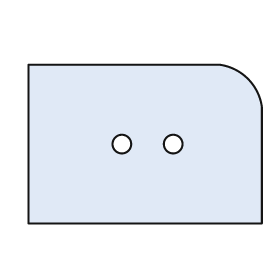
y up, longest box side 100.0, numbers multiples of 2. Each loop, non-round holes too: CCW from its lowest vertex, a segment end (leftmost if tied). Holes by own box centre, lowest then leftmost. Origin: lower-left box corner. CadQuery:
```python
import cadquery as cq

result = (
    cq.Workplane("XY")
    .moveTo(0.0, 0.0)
    .lineTo(100.0, 0.0)
    .lineTo(100.0, 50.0)
    .threePointArc((94.0, 62.0), (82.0, 68.0))
    .lineTo(0.0, 68.0)
    .close()
    .moveTo(40.0, 34.0)
    .circle(4.0)
    .moveTo(62.0, 34.0)
    .circle(4.0)
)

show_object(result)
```